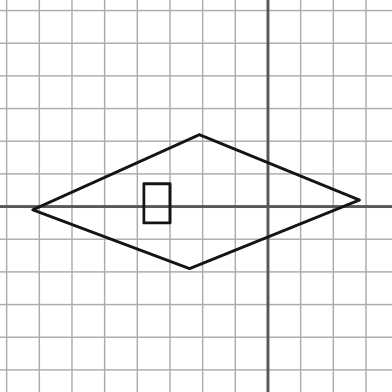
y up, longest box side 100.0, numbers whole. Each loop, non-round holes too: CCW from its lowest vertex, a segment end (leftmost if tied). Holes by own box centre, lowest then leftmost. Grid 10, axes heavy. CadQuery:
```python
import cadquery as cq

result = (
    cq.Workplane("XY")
    .moveTo(-24.0, -19.0)
    .lineTo(28.0, 2.0)
    .lineTo(-21.0, 22.0)
    .lineTo(-72.0, -1.0)
    .close()
    .moveTo(-38.0, -5.0)
    .lineTo(-30.0, -5.0)
    .lineTo(-30.0, 7.0)
    .lineTo(-38.0, 7.0)
    .close()
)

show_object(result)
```